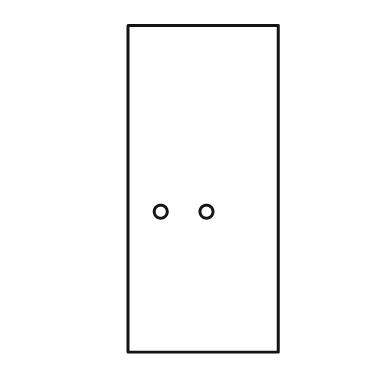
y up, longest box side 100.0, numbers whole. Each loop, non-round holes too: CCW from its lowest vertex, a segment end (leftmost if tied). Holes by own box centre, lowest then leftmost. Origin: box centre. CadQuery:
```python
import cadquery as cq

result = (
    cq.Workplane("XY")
    .moveTo(-23.0, -50.0)
    .lineTo(23.0, -50.0)
    .lineTo(23.0, 50.0)
    .lineTo(-23.0, 50.0)
    .close()
    .moveTo(-13.0, -7.0)
    .circle(2.0)
    .moveTo(1.0, -7.0)
    .circle(2.0)
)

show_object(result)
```